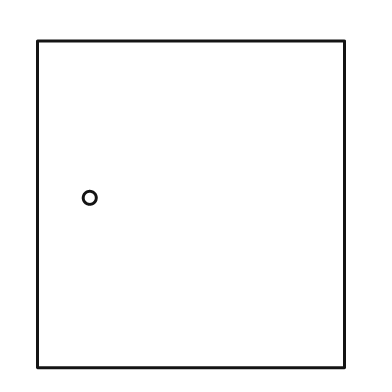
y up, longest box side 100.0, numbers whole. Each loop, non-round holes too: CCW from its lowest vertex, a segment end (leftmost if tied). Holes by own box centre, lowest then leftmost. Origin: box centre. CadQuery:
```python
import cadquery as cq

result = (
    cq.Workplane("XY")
    .moveTo(-47.0, -50.0)
    .lineTo(47.0, -50.0)
    .lineTo(47.0, 50.0)
    .lineTo(-47.0, 50.0)
    .close()
    .moveTo(-31.0, 2.0)
    .circle(2.0)
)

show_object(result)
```